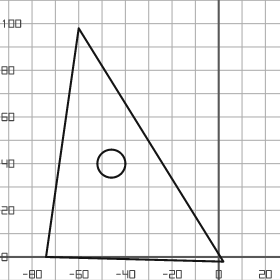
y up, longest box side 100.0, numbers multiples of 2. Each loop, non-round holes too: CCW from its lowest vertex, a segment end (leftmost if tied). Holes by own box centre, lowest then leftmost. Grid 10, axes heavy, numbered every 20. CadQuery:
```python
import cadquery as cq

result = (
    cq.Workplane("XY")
    .moveTo(2.0, -2.0)
    .lineTo(-60.0, 98.0)
    .lineTo(-74.0, 0.0)
    .close()
    .moveTo(-46.0, 40.0)
    .circle(6.0)
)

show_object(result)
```